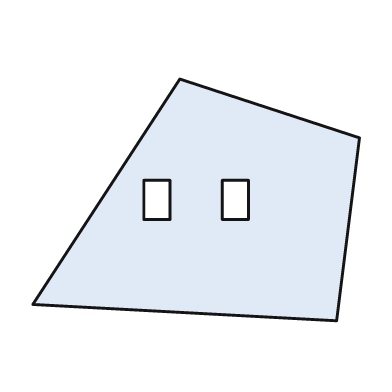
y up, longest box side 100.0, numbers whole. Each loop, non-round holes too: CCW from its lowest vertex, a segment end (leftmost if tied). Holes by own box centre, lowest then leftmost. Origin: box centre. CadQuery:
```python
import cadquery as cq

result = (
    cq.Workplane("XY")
    .moveTo(43.0, -37.0)
    .lineTo(50.0, 19.0)
    .lineTo(-5.0, 37.0)
    .lineTo(-50.0, -32.0)
    .close()
    .moveTo(-16.0, -6.0)
    .lineTo(-8.0, -6.0)
    .lineTo(-8.0, 6.0)
    .lineTo(-16.0, 6.0)
    .close()
    .moveTo(8.0, -6.0)
    .lineTo(16.0, -6.0)
    .lineTo(16.0, 6.0)
    .lineTo(8.0, 6.0)
    .close()
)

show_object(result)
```